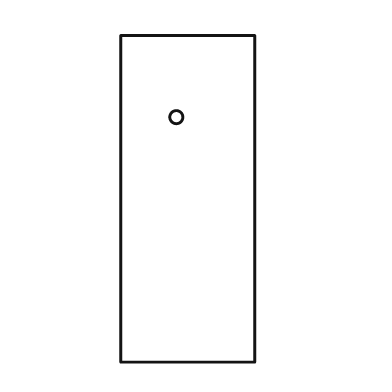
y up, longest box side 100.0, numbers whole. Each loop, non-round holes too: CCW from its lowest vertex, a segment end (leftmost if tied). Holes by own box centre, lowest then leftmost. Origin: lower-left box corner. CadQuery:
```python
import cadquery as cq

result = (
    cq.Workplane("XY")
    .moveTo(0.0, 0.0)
    .lineTo(41.0, 0.0)
    .lineTo(41.0, 100.0)
    .lineTo(0.0, 100.0)
    .close()
    .moveTo(17.0, 75.0)
    .circle(2.0)
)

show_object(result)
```